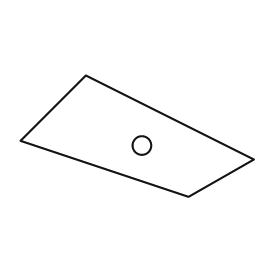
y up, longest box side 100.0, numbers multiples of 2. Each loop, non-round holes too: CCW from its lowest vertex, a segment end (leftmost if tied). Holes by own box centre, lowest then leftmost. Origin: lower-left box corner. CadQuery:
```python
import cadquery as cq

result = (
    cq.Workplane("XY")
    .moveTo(72.0, 0.0)
    .lineTo(100.0, 16.0)
    .lineTo(28.0, 52.0)
    .lineTo(0.0, 24.0)
    .close()
    .moveTo(52.0, 22.0)
    .circle(4.0)
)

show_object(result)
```